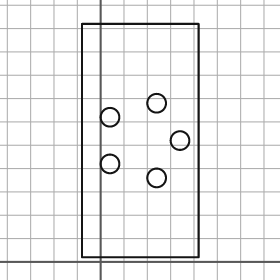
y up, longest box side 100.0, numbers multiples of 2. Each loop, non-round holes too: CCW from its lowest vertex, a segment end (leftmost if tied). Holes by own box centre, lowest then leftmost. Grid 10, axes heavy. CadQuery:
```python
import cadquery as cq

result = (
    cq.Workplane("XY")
    .moveTo(-8.0, 2.0)
    .lineTo(42.0, 2.0)
    .lineTo(42.0, 102.0)
    .lineTo(-8.0, 102.0)
    .close()
    .moveTo(24.0, 36.0)
    .circle(4.0)
    .moveTo(4.0, 42.0)
    .circle(4.0)
    .moveTo(34.0, 52.0)
    .circle(4.0)
    .moveTo(4.0, 62.0)
    .circle(4.0)
    .moveTo(24.0, 68.0)
    .circle(4.0)
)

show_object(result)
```